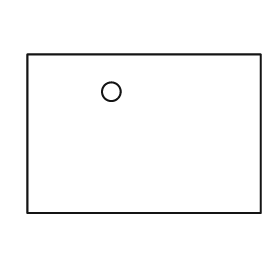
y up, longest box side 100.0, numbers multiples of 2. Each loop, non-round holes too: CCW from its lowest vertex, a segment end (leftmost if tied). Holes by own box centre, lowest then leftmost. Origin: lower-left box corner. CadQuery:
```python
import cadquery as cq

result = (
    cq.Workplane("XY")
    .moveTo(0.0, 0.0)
    .lineTo(100.0, 0.0)
    .lineTo(100.0, 68.0)
    .lineTo(0.0, 68.0)
    .close()
    .moveTo(36.0, 52.0)
    .circle(4.0)
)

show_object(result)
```